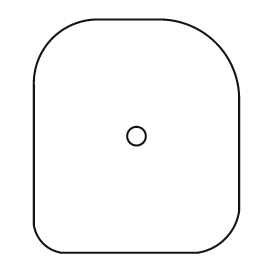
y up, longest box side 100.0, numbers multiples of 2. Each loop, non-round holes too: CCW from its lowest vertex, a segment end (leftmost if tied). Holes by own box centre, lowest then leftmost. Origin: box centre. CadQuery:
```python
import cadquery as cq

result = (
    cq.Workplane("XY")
    .moveTo(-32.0, -50.0)
    .lineTo(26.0, -50.0)
    .threePointArc((38.0, -44.0), (44.0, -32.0))
    .lineTo(44.0, 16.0)
    .threePointArc((34.0, 40.0), (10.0, 50.0))
    .lineTo(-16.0, 50.0)
    .threePointArc((-36.0, 42.0), (-44.0, 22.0))
    .lineTo(-44.0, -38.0)
    .threePointArc((-40.0, -46.0), (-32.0, -50.0))
    .close()
    .moveTo(0.0, 0.0)
    .circle(4.0)
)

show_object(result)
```